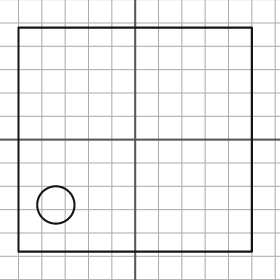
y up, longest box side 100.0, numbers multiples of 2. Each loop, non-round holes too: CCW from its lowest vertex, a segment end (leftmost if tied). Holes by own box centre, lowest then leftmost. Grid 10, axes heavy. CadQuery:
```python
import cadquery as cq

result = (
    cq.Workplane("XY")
    .moveTo(-50.0, -48.0)
    .lineTo(50.0, -48.0)
    .lineTo(50.0, 48.0)
    .lineTo(-50.0, 48.0)
    .close()
    .moveTo(-34.0, -28.0)
    .circle(8.0)
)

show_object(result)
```